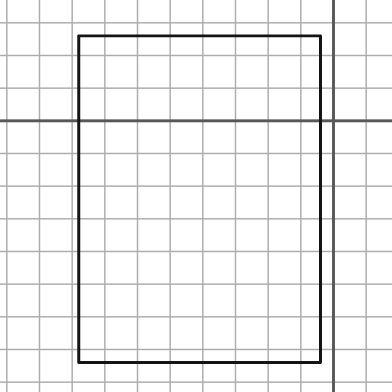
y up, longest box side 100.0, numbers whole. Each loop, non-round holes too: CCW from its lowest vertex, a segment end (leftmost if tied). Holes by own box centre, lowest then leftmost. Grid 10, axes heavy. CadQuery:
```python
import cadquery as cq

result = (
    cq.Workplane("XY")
    .moveTo(-78.0, -74.0)
    .lineTo(-4.0, -74.0)
    .lineTo(-4.0, 26.0)
    .lineTo(-78.0, 26.0)
    .close()
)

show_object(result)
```